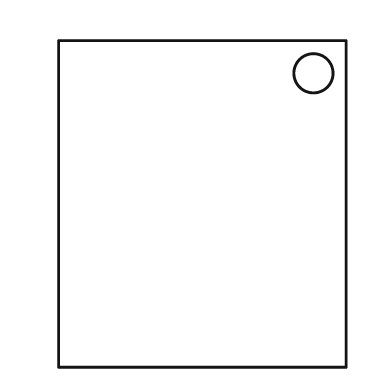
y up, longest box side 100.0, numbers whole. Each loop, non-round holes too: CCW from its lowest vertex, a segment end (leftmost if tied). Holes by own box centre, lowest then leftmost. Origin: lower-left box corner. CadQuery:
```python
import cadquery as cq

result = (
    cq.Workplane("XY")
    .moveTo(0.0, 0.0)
    .lineTo(88.0, 0.0)
    .lineTo(88.0, 100.0)
    .lineTo(0.0, 100.0)
    .close()
    .moveTo(78.0, 90.0)
    .circle(6.0)
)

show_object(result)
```